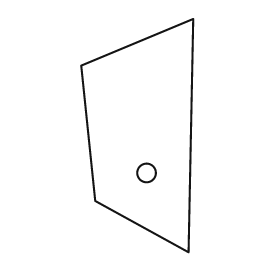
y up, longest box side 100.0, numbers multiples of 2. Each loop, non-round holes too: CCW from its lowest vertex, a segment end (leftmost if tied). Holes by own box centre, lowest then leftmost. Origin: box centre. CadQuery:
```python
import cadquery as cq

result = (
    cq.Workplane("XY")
    .moveTo(22.0, -50.0)
    .lineTo(24.0, 50.0)
    .lineTo(-24.0, 30.0)
    .lineTo(-18.0, -28.0)
    .close()
    .moveTo(4.0, -16.0)
    .circle(4.0)
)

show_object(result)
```